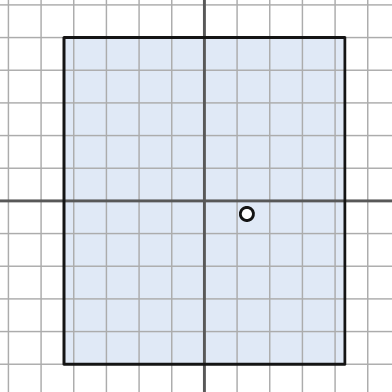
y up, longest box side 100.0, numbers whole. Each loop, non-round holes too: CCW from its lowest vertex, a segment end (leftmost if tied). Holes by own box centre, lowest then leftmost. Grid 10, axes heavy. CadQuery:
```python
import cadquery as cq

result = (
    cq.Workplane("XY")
    .moveTo(-43.0, -50.0)
    .lineTo(43.0, -50.0)
    .lineTo(43.0, 50.0)
    .lineTo(-43.0, 50.0)
    .close()
    .moveTo(13.0, -4.0)
    .circle(2.0)
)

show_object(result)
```